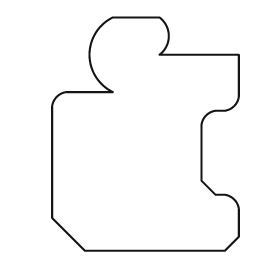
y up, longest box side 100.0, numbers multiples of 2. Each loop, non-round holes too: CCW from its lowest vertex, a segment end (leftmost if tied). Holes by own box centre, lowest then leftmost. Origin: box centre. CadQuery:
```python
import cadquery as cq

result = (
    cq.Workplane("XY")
    .moveTo(-26.0, -50.0)
    .lineTo(34.0, -50.0)
    .lineTo(40.0, -44.0)
    .lineTo(40.0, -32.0)
    .threePointArc((38.0, -28.0), (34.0, -26.0))
    .lineTo(30.0, -26.0)
    .lineTo(24.0, -20.0)
    .lineTo(24.0, 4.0)
    .threePointArc((26.0, 8.0), (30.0, 10.0))
    .lineTo(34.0, 10.0)
    .threePointArc((38.0, 12.0), (40.0, 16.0))
    .lineTo(40.0, 34.0)
    .lineTo(6.0, 34.0)
    .threePointArc((10.0, 42.0), (6.0, 50.0))
    .lineTo(-14.0, 50.0)
    .threePointArc((-24.0, 34.0), (-14.0, 18.0))
    .lineTo(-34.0, 18.0)
    .threePointArc((-38.0, 16.0), (-40.0, 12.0))
    .lineTo(-40.0, -36.0)
    .close()
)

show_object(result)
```